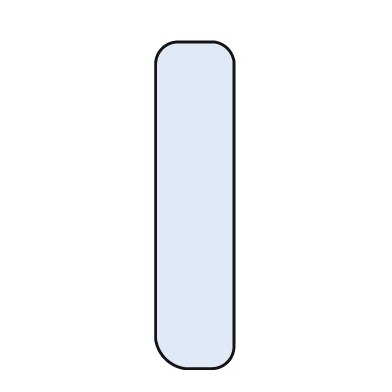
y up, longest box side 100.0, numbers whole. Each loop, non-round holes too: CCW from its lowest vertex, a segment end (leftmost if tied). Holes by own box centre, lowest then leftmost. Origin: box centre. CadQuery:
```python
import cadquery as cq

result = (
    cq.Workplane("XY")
    .moveTo(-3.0, -50.0)
    .lineTo(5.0, -50.0)
    .threePointArc((10.0, -48.0), (12.0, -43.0))
    .lineTo(12.0, 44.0)
    .threePointArc((10.0, 48.0), (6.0, 50.0))
    .lineTo(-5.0, 50.0)
    .threePointArc((-10.0, 48.0), (-12.0, 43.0))
    .lineTo(-12.0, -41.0)
    .threePointArc((-9.0, -47.0), (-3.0, -50.0))
    .close()
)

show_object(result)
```